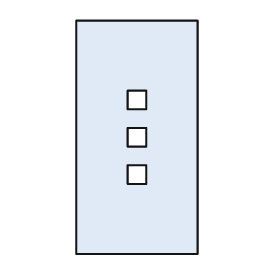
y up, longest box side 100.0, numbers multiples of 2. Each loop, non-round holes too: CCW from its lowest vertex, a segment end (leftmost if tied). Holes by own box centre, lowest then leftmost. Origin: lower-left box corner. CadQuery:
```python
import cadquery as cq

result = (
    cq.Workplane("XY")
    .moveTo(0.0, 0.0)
    .lineTo(52.0, 0.0)
    .lineTo(52.0, 100.0)
    .lineTo(0.0, 100.0)
    .close()
    .moveTo(22.0, 30.0)
    .lineTo(30.0, 30.0)
    .lineTo(30.0, 38.0)
    .lineTo(22.0, 38.0)
    .close()
    .moveTo(22.0, 46.0)
    .lineTo(30.0, 46.0)
    .lineTo(30.0, 54.0)
    .lineTo(22.0, 54.0)
    .close()
    .moveTo(22.0, 62.0)
    .lineTo(30.0, 62.0)
    .lineTo(30.0, 70.0)
    .lineTo(22.0, 70.0)
    .close()
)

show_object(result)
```